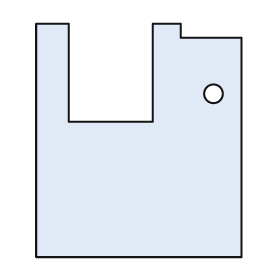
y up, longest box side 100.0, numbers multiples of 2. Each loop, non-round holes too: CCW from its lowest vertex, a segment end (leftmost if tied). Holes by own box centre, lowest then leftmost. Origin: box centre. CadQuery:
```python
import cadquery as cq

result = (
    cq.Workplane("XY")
    .moveTo(-44.0, -50.0)
    .lineTo(44.0, -50.0)
    .lineTo(44.0, 44.0)
    .lineTo(18.0, 44.0)
    .lineTo(18.0, 50.0)
    .lineTo(6.0, 50.0)
    .lineTo(6.0, 8.0)
    .lineTo(-30.0, 8.0)
    .lineTo(-30.0, 50.0)
    .lineTo(-44.0, 50.0)
    .close()
    .moveTo(32.0, 20.0)
    .circle(4.0)
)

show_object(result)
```